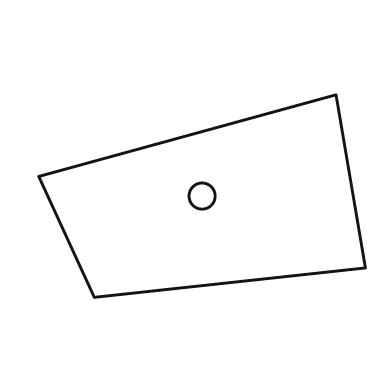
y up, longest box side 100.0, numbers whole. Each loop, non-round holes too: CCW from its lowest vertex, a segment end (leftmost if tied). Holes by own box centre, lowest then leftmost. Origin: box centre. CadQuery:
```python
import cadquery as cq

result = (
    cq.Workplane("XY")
    .moveTo(-33.0, -31.0)
    .lineTo(50.0, -22.0)
    .lineTo(41.0, 31.0)
    .lineTo(-50.0, 6.0)
    .close()
    .moveTo(0.0, 0.0)
    .circle(4.0)
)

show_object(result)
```